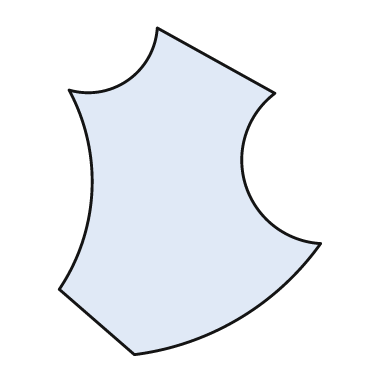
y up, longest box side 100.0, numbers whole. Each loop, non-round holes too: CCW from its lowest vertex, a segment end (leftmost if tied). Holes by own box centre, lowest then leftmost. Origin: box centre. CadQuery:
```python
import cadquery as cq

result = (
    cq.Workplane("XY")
    .moveTo(-17.0, -50.0)
    .threePointArc((15.0, -39.0), (40.0, -16.0))
    .threePointArc((17.0, 2.0), (26.0, 30.0))
    .lineTo(-10.0, 50.0)
    .threePointArc((-19.0, 34.0), (-37.0, 31.0))
    .threePointArc((-30.0, 0.0), (-40.0, -30.0))
    .close()
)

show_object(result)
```